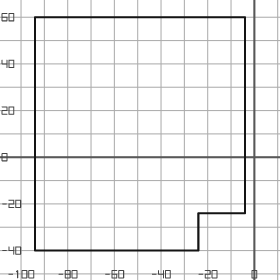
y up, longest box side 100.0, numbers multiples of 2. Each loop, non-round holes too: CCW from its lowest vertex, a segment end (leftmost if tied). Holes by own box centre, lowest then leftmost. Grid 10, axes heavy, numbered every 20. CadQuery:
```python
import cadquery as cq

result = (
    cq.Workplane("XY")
    .moveTo(-94.0, -40.0)
    .lineTo(-24.0, -40.0)
    .lineTo(-24.0, -24.0)
    .lineTo(-4.0, -24.0)
    .lineTo(-4.0, 60.0)
    .lineTo(-94.0, 60.0)
    .close()
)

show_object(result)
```